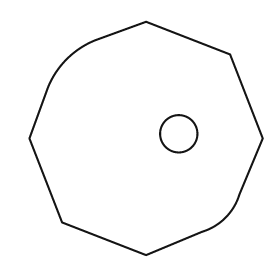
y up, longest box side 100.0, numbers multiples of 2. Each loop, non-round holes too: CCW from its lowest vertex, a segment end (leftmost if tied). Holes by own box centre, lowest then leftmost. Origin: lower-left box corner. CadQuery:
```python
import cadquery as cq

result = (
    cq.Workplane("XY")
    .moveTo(50.0, 0.0)
    .lineTo(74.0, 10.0)
    .threePointArc((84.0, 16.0), (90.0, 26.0))
    .lineTo(100.0, 50.0)
    .lineTo(86.0, 86.0)
    .lineTo(50.0, 100.0)
    .lineTo(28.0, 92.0)
    .threePointArc((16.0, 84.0), (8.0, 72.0))
    .lineTo(0.0, 50.0)
    .lineTo(14.0, 14.0)
    .close()
    .moveTo(64.0, 52.0)
    .circle(8.0)
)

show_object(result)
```